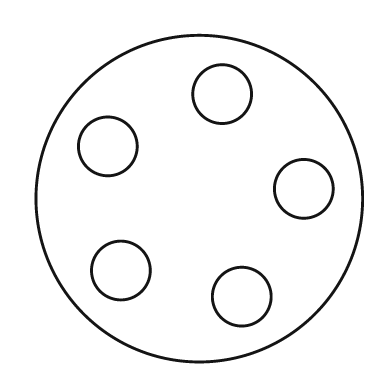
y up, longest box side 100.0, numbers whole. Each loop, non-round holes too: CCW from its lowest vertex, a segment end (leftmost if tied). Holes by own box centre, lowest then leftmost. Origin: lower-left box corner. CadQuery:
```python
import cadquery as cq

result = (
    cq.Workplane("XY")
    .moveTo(50.0, 50.0)
    .circle(50.0)
    .moveTo(63.0, 20.0)
    .circle(9.0)
    .moveTo(26.0, 28.0)
    .circle(9.0)
    .moveTo(82.0, 53.0)
    .circle(9.0)
    .moveTo(22.0, 66.0)
    .circle(9.0)
    .moveTo(57.0, 82.0)
    .circle(9.0)
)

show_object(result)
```